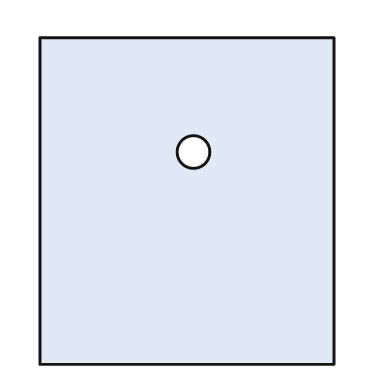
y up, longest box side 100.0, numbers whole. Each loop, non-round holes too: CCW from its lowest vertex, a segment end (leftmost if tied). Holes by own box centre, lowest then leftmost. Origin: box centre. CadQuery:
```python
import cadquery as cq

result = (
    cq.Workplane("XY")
    .moveTo(-45.0, -50.0)
    .lineTo(45.0, -50.0)
    .lineTo(45.0, 50.0)
    .lineTo(-45.0, 50.0)
    .close()
    .moveTo(2.0, 15.0)
    .circle(5.0)
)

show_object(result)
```